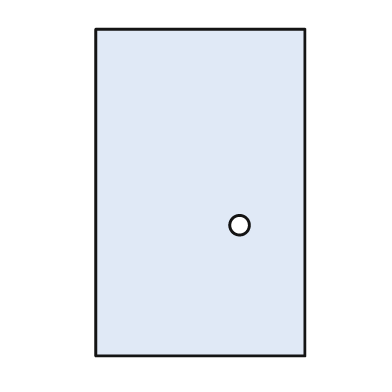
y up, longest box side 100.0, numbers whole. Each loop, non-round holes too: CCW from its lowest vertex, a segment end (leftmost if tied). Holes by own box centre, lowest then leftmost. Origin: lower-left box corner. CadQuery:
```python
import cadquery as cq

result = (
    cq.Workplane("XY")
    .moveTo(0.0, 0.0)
    .lineTo(64.0, 0.0)
    .lineTo(64.0, 100.0)
    .lineTo(0.0, 100.0)
    .close()
    .moveTo(44.0, 40.0)
    .circle(3.0)
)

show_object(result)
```